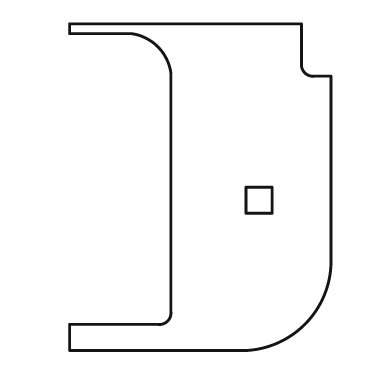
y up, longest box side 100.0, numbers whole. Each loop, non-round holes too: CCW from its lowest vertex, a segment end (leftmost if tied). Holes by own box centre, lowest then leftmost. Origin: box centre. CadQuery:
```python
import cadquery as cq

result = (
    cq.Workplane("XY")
    .moveTo(-40.0, -50.0)
    .lineTo(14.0, -50.0)
    .threePointArc((32.0, -42.0), (40.0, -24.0))
    .lineTo(40.0, 34.0)
    .lineTo(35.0, 34.0)
    .threePointArc((32.0, 35.0), (31.0, 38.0))
    .lineTo(31.0, 50.0)
    .lineTo(-40.0, 50.0)
    .lineTo(-40.0, 47.0)
    .lineTo(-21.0, 47.0)
    .threePointArc((-13.0, 43.0), (-9.0, 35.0))
    .lineTo(-9.0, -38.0)
    .threePointArc((-10.0, -41.0), (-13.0, -42.0))
    .lineTo(-40.0, -42.0)
    .close()
    .moveTo(14.0, -8.0)
    .lineTo(22.0, -8.0)
    .lineTo(22.0, 0.0)
    .lineTo(14.0, 0.0)
    .close()
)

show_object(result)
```